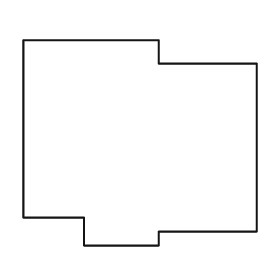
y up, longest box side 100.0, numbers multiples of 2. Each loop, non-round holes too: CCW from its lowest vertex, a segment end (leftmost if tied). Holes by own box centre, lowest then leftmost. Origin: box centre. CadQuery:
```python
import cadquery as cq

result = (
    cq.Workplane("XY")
    .moveTo(-24.0, -44.0)
    .lineTo(8.0, -44.0)
    .lineTo(8.0, -38.0)
    .lineTo(50.0, -38.0)
    .lineTo(50.0, 34.0)
    .lineTo(8.0, 34.0)
    .lineTo(8.0, 44.0)
    .lineTo(-50.0, 44.0)
    .lineTo(-50.0, -32.0)
    .lineTo(-24.0, -32.0)
    .close()
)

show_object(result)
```